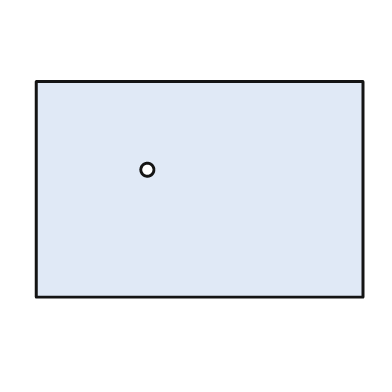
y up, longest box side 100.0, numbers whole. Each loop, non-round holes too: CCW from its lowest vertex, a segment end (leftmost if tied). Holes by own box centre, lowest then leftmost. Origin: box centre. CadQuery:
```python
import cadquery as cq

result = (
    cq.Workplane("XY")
    .moveTo(-50.0, -33.0)
    .lineTo(50.0, -33.0)
    .lineTo(50.0, 33.0)
    .lineTo(-50.0, 33.0)
    .close()
    .moveTo(-16.0, 6.0)
    .circle(2.0)
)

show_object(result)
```